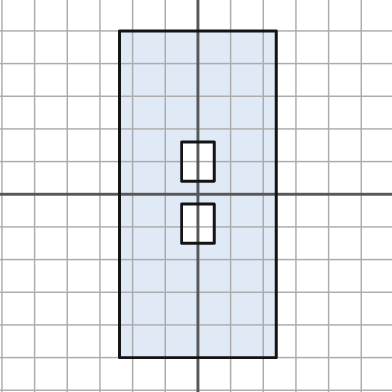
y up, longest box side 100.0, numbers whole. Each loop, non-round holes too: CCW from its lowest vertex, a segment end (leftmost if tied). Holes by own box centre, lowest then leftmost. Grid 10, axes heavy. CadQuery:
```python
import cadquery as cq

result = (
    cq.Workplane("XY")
    .moveTo(-24.0, -50.0)
    .lineTo(24.0, -50.0)
    .lineTo(24.0, 50.0)
    .lineTo(-24.0, 50.0)
    .close()
    .moveTo(-5.0, -15.0)
    .lineTo(5.0, -15.0)
    .lineTo(5.0, -3.0)
    .lineTo(-5.0, -3.0)
    .close()
    .moveTo(-5.0, 4.0)
    .lineTo(5.0, 4.0)
    .lineTo(5.0, 16.0)
    .lineTo(-5.0, 16.0)
    .close()
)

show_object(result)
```